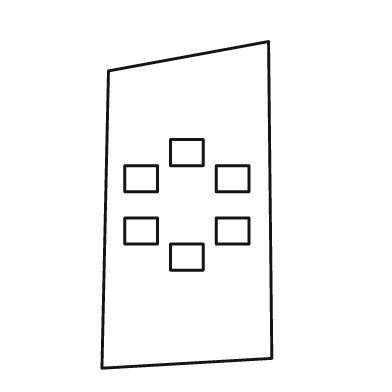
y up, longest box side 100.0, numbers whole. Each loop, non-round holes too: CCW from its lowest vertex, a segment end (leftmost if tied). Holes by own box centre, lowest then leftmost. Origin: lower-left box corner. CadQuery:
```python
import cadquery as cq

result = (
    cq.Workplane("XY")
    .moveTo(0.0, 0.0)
    .lineTo(52.0, 3.0)
    .lineTo(51.0, 100.0)
    .lineTo(2.0, 91.0)
    .close()
    .moveTo(21.0, 30.0)
    .lineTo(31.0, 30.0)
    .lineTo(31.0, 38.0)
    .lineTo(21.0, 38.0)
    .close()
    .moveTo(7.0, 38.0)
    .lineTo(17.0, 38.0)
    .lineTo(17.0, 46.0)
    .lineTo(7.0, 46.0)
    .close()
    .moveTo(35.0, 38.0)
    .lineTo(45.0, 38.0)
    .lineTo(45.0, 46.0)
    .lineTo(35.0, 46.0)
    .close()
    .moveTo(7.0, 54.0)
    .lineTo(17.0, 54.0)
    .lineTo(17.0, 62.0)
    .lineTo(7.0, 62.0)
    .close()
    .moveTo(35.0, 54.0)
    .lineTo(45.0, 54.0)
    .lineTo(45.0, 62.0)
    .lineTo(35.0, 62.0)
    .close()
    .moveTo(21.0, 62.0)
    .lineTo(31.0, 62.0)
    .lineTo(31.0, 70.0)
    .lineTo(21.0, 70.0)
    .close()
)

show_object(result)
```